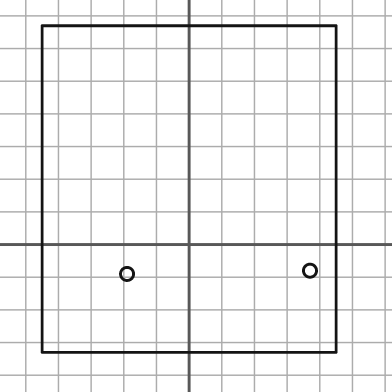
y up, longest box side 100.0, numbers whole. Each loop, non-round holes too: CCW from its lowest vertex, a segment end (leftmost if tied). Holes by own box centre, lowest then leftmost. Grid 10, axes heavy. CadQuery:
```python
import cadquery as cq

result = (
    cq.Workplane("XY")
    .moveTo(-45.0, -33.0)
    .lineTo(45.0, -33.0)
    .lineTo(45.0, 67.0)
    .lineTo(-45.0, 67.0)
    .close()
    .moveTo(-19.0, -9.0)
    .circle(2.0)
    .moveTo(37.0, -8.0)
    .circle(2.0)
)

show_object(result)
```